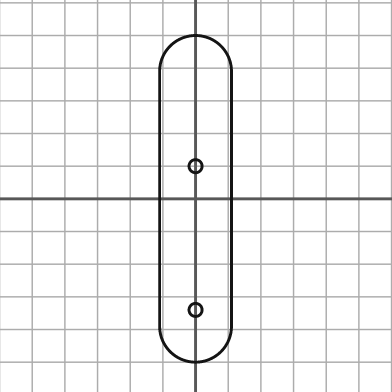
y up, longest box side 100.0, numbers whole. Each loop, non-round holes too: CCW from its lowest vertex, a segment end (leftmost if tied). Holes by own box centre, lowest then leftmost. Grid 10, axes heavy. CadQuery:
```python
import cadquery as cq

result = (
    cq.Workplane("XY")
    .moveTo(-11.0, -39.0)
    .threePointArc((0.0, -50.0), (11.0, -39.0))
    .lineTo(11.0, 39.0)
    .threePointArc((0.0, 50.0), (-11.0, 39.0))
    .close()
    .moveTo(0.0, -34.0)
    .circle(2.0)
    .moveTo(0.0, 10.0)
    .circle(2.0)
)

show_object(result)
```